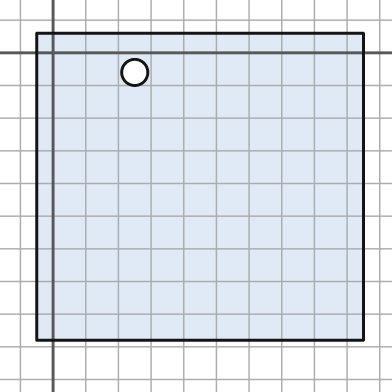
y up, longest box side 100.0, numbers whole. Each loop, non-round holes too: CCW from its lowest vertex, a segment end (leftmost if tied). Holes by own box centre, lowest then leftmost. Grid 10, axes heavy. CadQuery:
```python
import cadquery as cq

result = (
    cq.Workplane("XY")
    .moveTo(-5.0, -88.0)
    .lineTo(95.0, -88.0)
    .lineTo(95.0, 6.0)
    .lineTo(-5.0, 6.0)
    .close()
    .moveTo(25.0, -6.0)
    .circle(4.0)
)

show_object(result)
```